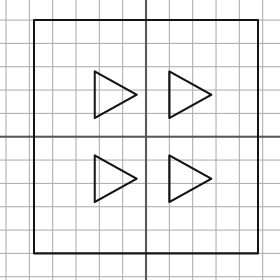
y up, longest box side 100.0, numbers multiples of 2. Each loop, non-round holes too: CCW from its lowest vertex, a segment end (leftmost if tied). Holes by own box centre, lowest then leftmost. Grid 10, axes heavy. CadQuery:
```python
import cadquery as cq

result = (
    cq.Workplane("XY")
    .moveTo(-48.0, -50.0)
    .lineTo(48.0, -50.0)
    .lineTo(48.0, 50.0)
    .lineTo(-48.0, 50.0)
    .close()
    .moveTo(-22.0, -28.0)
    .lineTo(-4.0, -18.0)
    .lineTo(-22.0, -8.0)
    .close()
    .moveTo(10.0, -28.0)
    .lineTo(28.0, -18.0)
    .lineTo(10.0, -8.0)
    .close()
    .moveTo(-22.0, 8.0)
    .lineTo(-4.0, 18.0)
    .lineTo(-22.0, 28.0)
    .close()
    .moveTo(10.0, 8.0)
    .lineTo(28.0, 18.0)
    .lineTo(10.0, 28.0)
    .close()
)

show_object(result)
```